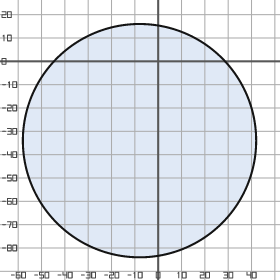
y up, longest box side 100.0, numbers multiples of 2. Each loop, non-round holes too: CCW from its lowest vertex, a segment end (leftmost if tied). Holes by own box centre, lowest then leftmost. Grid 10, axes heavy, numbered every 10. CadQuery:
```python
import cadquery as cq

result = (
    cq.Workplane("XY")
    .moveTo(-8.0, -34.0)
    .circle(50.0)
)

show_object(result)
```